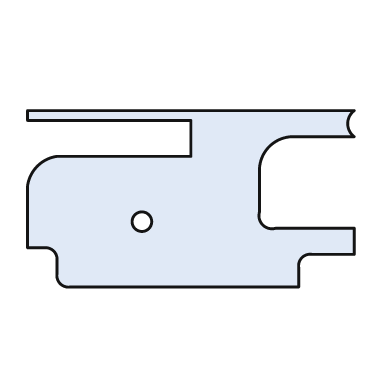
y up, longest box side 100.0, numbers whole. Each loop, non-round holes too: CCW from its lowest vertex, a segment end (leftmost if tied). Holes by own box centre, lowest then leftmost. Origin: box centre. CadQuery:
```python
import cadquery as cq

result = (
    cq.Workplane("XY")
    .moveTo(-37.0, -27.0)
    .lineTo(33.0, -27.0)
    .lineTo(33.0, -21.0)
    .threePointArc((34.0, -18.0), (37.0, -17.0))
    .lineTo(50.0, -17.0)
    .lineTo(50.0, -9.0)
    .lineTo(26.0, -9.0)
    .threePointArc((22.0, -8.0), (21.0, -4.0))
    .lineTo(21.0, 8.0)
    .threePointArc((24.0, 16.0), (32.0, 19.0))
    .lineTo(50.0, 19.0)
    .threePointArc((48.0, 23.0), (50.0, 27.0))
    .lineTo(-50.0, 27.0)
    .lineTo(-50.0, 24.0)
    .lineTo(0.0, 24.0)
    .lineTo(0.0, 13.0)
    .lineTo(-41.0, 13.0)
    .threePointArc((-47.0, 10.0), (-50.0, 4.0))
    .lineTo(-50.0, -15.0)
    .lineTo(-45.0, -15.0)
    .threePointArc((-42.0, -16.0), (-41.0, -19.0))
    .lineTo(-41.0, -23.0)
    .threePointArc((-40.0, -26.0), (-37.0, -27.0))
    .close()
    .moveTo(-15.0, -7.0)
    .circle(3.0)
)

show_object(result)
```